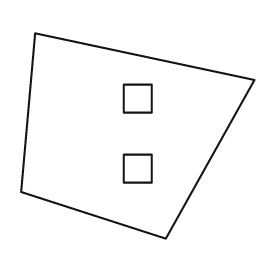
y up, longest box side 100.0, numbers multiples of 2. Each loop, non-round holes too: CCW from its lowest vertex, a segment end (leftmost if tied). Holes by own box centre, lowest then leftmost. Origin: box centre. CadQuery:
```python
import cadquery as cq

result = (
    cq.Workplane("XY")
    .moveTo(12.0, -44.0)
    .lineTo(50.0, 24.0)
    .lineTo(-44.0, 44.0)
    .lineTo(-50.0, -24.0)
    .close()
    .moveTo(-6.0, -20.0)
    .lineTo(6.0, -20.0)
    .lineTo(6.0, -8.0)
    .lineTo(-6.0, -8.0)
    .close()
    .moveTo(-6.0, 10.0)
    .lineTo(6.0, 10.0)
    .lineTo(6.0, 22.0)
    .lineTo(-6.0, 22.0)
    .close()
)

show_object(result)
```